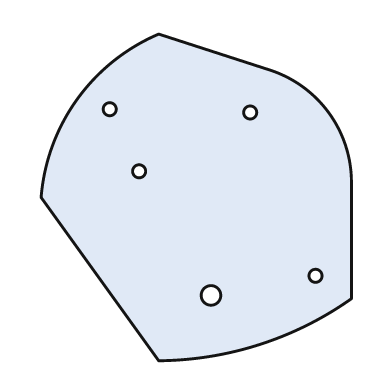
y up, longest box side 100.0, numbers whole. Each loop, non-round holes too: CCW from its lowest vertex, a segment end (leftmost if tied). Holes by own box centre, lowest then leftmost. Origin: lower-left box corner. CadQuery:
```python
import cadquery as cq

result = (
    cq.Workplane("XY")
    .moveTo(36.0, 0.0)
    .threePointArc((67.0, 5.0), (95.0, 19.0))
    .lineTo(95.0, 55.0)
    .threePointArc((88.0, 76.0), (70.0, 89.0))
    .lineTo(36.0, 100.0)
    .threePointArc((11.0, 80.0), (0.0, 50.0))
    .close()
    .moveTo(52.0, 20.0)
    .circle(3.0)
    .moveTo(84.0, 26.0)
    .circle(2.0)
    .moveTo(30.0, 58.0)
    .circle(2.0)
    .moveTo(64.0, 76.0)
    .circle(2.0)
    .moveTo(21.0, 77.0)
    .circle(2.0)
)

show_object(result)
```